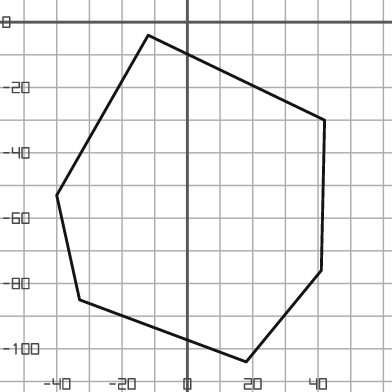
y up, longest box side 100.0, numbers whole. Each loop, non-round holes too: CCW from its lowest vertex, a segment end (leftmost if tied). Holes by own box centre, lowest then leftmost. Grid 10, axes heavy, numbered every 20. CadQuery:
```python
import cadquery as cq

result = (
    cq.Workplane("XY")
    .moveTo(18.0, -104.0)
    .lineTo(41.0, -76.0)
    .lineTo(42.0, -30.0)
    .lineTo(-12.0, -4.0)
    .lineTo(-40.0, -53.0)
    .lineTo(-33.0, -85.0)
    .close()
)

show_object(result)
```